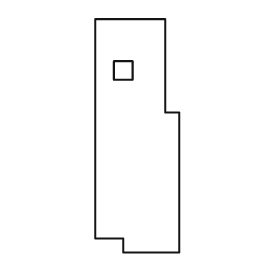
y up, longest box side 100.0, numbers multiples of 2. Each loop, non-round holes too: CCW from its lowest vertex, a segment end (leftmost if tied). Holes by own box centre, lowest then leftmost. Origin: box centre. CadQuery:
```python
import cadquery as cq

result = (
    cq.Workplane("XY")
    .moveTo(-6.0, -50.0)
    .lineTo(18.0, -50.0)
    .lineTo(18.0, 10.0)
    .lineTo(12.0, 10.0)
    .lineTo(12.0, 50.0)
    .lineTo(-18.0, 50.0)
    .lineTo(-18.0, -44.0)
    .lineTo(-6.0, -44.0)
    .close()
    .moveTo(-10.0, 24.0)
    .lineTo(-2.0, 24.0)
    .lineTo(-2.0, 32.0)
    .lineTo(-10.0, 32.0)
    .close()
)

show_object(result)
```